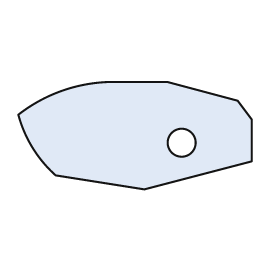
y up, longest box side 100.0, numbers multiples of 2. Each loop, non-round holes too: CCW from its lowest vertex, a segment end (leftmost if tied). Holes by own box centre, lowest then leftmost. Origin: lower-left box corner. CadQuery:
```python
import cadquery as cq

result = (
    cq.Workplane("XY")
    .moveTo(54.0, 0.0)
    .lineTo(100.0, 12.0)
    .lineTo(100.0, 30.0)
    .lineTo(94.0, 38.0)
    .lineTo(64.0, 46.0)
    .lineTo(38.0, 46.0)
    .threePointArc((18.0, 42.0), (0.0, 32.0))
    .threePointArc((6.0, 18.0), (16.0, 6.0))
    .close()
    .moveTo(70.0, 20.0)
    .circle(6.0)
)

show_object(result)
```